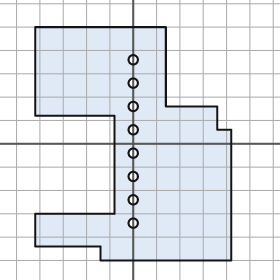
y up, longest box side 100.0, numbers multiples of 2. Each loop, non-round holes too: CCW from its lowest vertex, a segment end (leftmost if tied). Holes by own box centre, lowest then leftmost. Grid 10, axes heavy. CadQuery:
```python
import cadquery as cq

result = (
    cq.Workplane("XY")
    .moveTo(-14.0, -50.0)
    .lineTo(42.0, -50.0)
    .lineTo(42.0, 6.0)
    .lineTo(36.0, 6.0)
    .lineTo(36.0, 16.0)
    .lineTo(14.0, 16.0)
    .lineTo(14.0, 50.0)
    .lineTo(-42.0, 50.0)
    .lineTo(-42.0, 12.0)
    .lineTo(-8.0, 12.0)
    .lineTo(-8.0, -30.0)
    .lineTo(-42.0, -30.0)
    .lineTo(-42.0, -44.0)
    .lineTo(-14.0, -44.0)
    .close()
    .moveTo(0.0, -34.0)
    .circle(2.0)
    .moveTo(0.0, -24.0)
    .circle(2.0)
    .moveTo(0.0, -14.0)
    .circle(2.0)
    .moveTo(0.0, -4.0)
    .circle(2.0)
    .moveTo(0.0, 6.0)
    .circle(2.0)
    .moveTo(0.0, 16.0)
    .circle(2.0)
    .moveTo(0.0, 26.0)
    .circle(2.0)
    .moveTo(0.0, 36.0)
    .circle(2.0)
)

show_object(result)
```